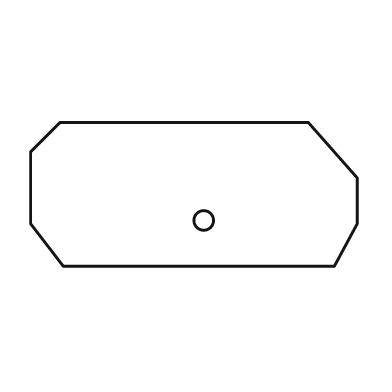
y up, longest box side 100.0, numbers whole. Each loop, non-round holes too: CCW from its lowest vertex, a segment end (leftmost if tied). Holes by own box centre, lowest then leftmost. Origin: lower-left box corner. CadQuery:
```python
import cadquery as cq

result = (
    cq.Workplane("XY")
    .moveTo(10.0, 0.0)
    .lineTo(93.0, 0.0)
    .lineTo(100.0, 13.0)
    .lineTo(100.0, 27.0)
    .lineTo(85.0, 44.0)
    .lineTo(9.0, 44.0)
    .lineTo(0.0, 35.0)
    .lineTo(0.0, 13.0)
    .close()
    .moveTo(53.0, 14.0)
    .circle(3.0)
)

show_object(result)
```